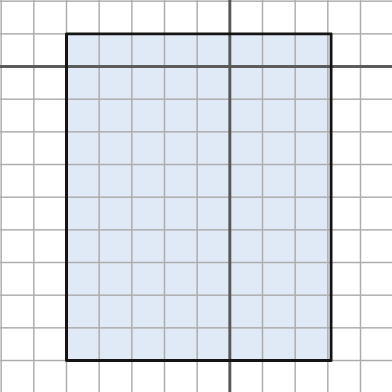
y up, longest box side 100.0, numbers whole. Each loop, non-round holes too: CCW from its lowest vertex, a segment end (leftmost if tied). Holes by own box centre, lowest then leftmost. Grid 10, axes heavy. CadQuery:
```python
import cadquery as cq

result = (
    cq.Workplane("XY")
    .moveTo(-50.0, -90.0)
    .lineTo(31.0, -90.0)
    .lineTo(31.0, 10.0)
    .lineTo(-50.0, 10.0)
    .close()
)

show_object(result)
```